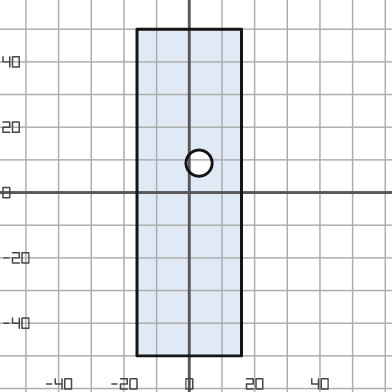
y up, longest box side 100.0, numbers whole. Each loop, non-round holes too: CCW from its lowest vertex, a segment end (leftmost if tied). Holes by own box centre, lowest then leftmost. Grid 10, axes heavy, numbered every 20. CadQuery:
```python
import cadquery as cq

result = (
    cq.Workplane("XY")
    .moveTo(-16.0, -50.0)
    .lineTo(16.0, -50.0)
    .lineTo(16.0, 50.0)
    .lineTo(-16.0, 50.0)
    .close()
    .moveTo(3.0, 9.0)
    .circle(4.0)
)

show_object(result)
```